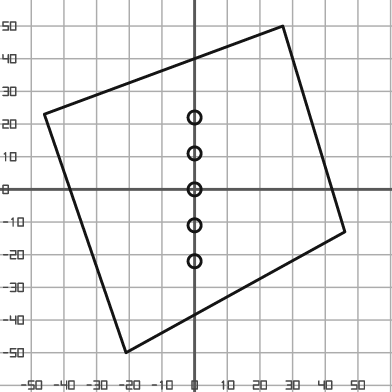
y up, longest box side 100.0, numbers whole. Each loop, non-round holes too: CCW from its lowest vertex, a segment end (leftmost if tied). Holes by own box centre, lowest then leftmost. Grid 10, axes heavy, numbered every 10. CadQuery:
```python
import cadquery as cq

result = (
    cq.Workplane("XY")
    .moveTo(-21.0, -50.0)
    .lineTo(46.0, -13.0)
    .lineTo(27.0, 50.0)
    .lineTo(-46.0, 23.0)
    .close()
    .moveTo(0.0, -22.0)
    .circle(2.0)
    .moveTo(0.0, -11.0)
    .circle(2.0)
    .moveTo(0.0, 0.0)
    .circle(2.0)
    .moveTo(0.0, 11.0)
    .circle(2.0)
    .moveTo(0.0, 22.0)
    .circle(2.0)
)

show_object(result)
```